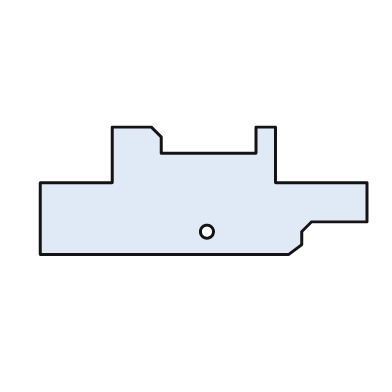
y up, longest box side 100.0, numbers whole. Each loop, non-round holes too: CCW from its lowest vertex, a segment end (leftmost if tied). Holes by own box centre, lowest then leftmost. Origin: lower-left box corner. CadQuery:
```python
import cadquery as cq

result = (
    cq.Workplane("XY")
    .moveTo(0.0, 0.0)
    .lineTo(76.0, 0.0)
    .lineTo(80.0, 3.0)
    .lineTo(80.0, 7.0)
    .lineTo(83.0, 10.0)
    .lineTo(100.0, 10.0)
    .lineTo(100.0, 22.0)
    .lineTo(72.0, 22.0)
    .lineTo(72.0, 39.0)
    .lineTo(66.0, 39.0)
    .lineTo(66.0, 31.0)
    .lineTo(37.0, 31.0)
    .lineTo(37.0, 36.0)
    .lineTo(34.0, 39.0)
    .lineTo(22.0, 39.0)
    .lineTo(22.0, 22.0)
    .lineTo(0.0, 22.0)
    .close()
    .moveTo(51.0, 7.0)
    .circle(2.0)
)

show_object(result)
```